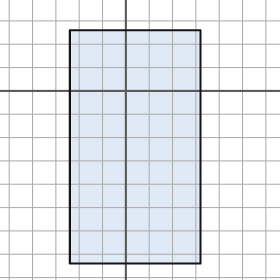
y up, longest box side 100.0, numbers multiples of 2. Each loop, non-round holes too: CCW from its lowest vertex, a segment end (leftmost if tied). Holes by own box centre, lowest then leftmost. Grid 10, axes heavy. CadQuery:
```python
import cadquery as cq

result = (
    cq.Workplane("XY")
    .moveTo(-24.0, -74.0)
    .lineTo(32.0, -74.0)
    .lineTo(32.0, 26.0)
    .lineTo(-24.0, 26.0)
    .close()
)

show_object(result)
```